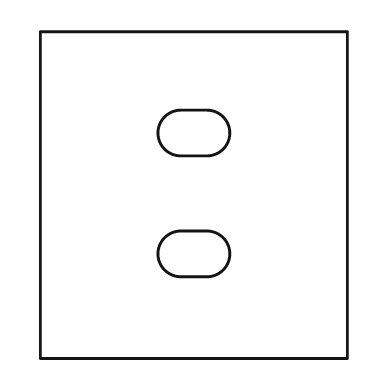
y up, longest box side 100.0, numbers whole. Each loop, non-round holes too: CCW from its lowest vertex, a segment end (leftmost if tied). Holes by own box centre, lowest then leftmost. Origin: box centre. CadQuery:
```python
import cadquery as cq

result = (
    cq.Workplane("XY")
    .moveTo(-47.0, -50.0)
    .lineTo(47.0, -50.0)
    .lineTo(47.0, 50.0)
    .lineTo(-47.0, 50.0)
    .close()
    .moveTo(-4.0, -25.0)
    .lineTo(4.0, -25.0)
    .threePointArc((11.0, -18.0), (4.0, -11.0))
    .lineTo(-4.0, -11.0)
    .threePointArc((-11.0, -18.0), (-4.0, -25.0))
    .close()
    .moveTo(-4.0, 12.0)
    .lineTo(4.0, 12.0)
    .threePointArc((11.0, 19.0), (4.0, 26.0))
    .lineTo(-4.0, 26.0)
    .threePointArc((-11.0, 19.0), (-4.0, 12.0))
    .close()
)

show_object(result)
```